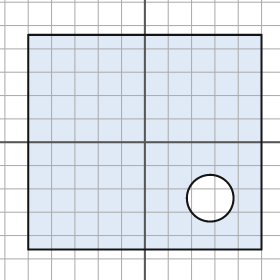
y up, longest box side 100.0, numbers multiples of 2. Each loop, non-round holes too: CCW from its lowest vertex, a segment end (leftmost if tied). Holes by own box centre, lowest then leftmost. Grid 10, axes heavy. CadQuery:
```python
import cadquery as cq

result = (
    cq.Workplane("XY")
    .moveTo(-50.0, -46.0)
    .lineTo(50.0, -46.0)
    .lineTo(50.0, 46.0)
    .lineTo(-50.0, 46.0)
    .close()
    .moveTo(28.0, -24.0)
    .circle(10.0)
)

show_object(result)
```